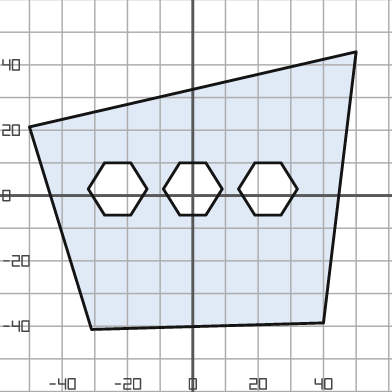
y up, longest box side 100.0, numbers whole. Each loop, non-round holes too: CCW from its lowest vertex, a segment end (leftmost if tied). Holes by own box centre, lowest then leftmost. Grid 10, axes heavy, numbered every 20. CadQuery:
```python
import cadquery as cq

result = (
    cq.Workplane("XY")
    .moveTo(-31.0, -41.0)
    .lineTo(40.0, -39.0)
    .lineTo(50.0, 44.0)
    .lineTo(-50.0, 21.0)
    .close()
    .moveTo(-27.0, -6.0)
    .lineTo(-19.0, -6.0)
    .lineTo(-14.0, 2.0)
    .lineTo(-19.0, 10.0)
    .lineTo(-27.0, 10.0)
    .lineTo(-32.0, 2.0)
    .close()
    .moveTo(-4.0, -6.0)
    .lineTo(4.0, -6.0)
    .lineTo(9.0, 2.0)
    .lineTo(4.0, 10.0)
    .lineTo(-4.0, 10.0)
    .lineTo(-9.0, 2.0)
    .close()
    .moveTo(19.0, -6.0)
    .lineTo(27.0, -6.0)
    .lineTo(32.0, 2.0)
    .lineTo(27.0, 10.0)
    .lineTo(19.0, 10.0)
    .lineTo(14.0, 2.0)
    .close()
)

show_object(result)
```